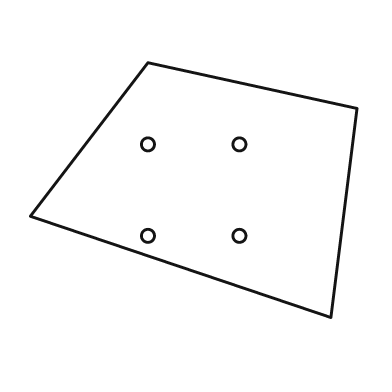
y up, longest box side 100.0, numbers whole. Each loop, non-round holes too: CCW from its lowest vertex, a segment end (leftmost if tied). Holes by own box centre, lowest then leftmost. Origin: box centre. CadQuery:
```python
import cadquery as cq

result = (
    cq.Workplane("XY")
    .moveTo(42.0, -39.0)
    .lineTo(50.0, 25.0)
    .lineTo(-14.0, 39.0)
    .lineTo(-50.0, -8.0)
    .close()
    .moveTo(-14.0, -14.0)
    .circle(2.0)
    .moveTo(14.0, -14.0)
    .circle(2.0)
    .moveTo(-14.0, 14.0)
    .circle(2.0)
    .moveTo(14.0, 14.0)
    .circle(2.0)
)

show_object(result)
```